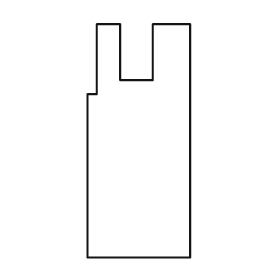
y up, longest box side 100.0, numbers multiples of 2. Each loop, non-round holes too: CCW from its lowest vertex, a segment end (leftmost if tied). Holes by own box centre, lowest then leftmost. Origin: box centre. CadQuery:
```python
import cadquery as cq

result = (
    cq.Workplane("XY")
    .moveTo(-22.0, -50.0)
    .lineTo(22.0, -50.0)
    .lineTo(22.0, 50.0)
    .lineTo(6.0, 50.0)
    .lineTo(6.0, 26.0)
    .lineTo(-8.0, 26.0)
    .lineTo(-8.0, 50.0)
    .lineTo(-18.0, 50.0)
    .lineTo(-18.0, 20.0)
    .lineTo(-22.0, 20.0)
    .close()
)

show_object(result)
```